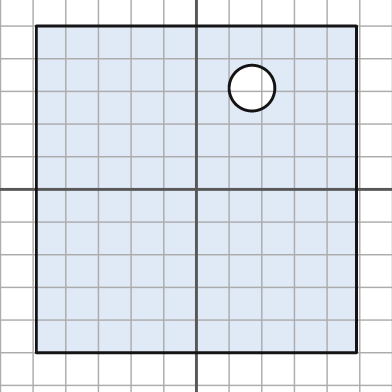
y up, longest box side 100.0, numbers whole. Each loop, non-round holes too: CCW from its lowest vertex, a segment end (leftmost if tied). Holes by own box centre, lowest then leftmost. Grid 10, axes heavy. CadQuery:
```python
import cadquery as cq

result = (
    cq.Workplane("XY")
    .moveTo(-49.0, -50.0)
    .lineTo(49.0, -50.0)
    .lineTo(49.0, 50.0)
    .lineTo(-49.0, 50.0)
    .close()
    .moveTo(17.0, 31.0)
    .circle(7.0)
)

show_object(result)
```